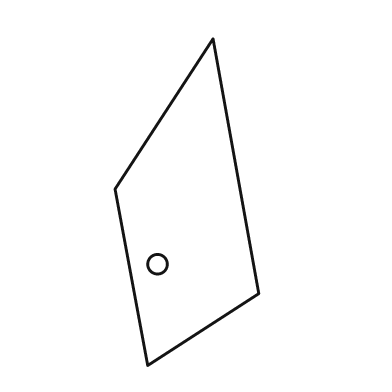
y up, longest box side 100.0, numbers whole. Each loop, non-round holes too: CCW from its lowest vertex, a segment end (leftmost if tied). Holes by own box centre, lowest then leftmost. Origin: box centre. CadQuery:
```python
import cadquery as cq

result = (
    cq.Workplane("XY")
    .moveTo(-12.0, -50.0)
    .lineTo(22.0, -28.0)
    .lineTo(8.0, 50.0)
    .lineTo(-22.0, 4.0)
    .close()
    .moveTo(-9.0, -19.0)
    .circle(3.0)
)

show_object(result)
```